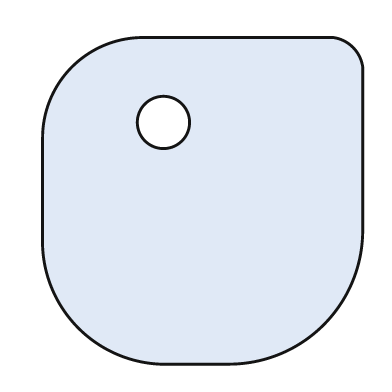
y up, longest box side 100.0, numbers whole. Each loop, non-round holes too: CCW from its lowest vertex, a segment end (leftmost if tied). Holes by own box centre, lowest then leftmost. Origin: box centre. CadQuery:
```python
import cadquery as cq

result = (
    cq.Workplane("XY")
    .moveTo(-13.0, -50.0)
    .lineTo(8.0, -50.0)
    .threePointArc((37.0, -38.0), (49.0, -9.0))
    .lineTo(49.0, 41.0)
    .threePointArc((46.0, 47.0), (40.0, 50.0))
    .lineTo(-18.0, 50.0)
    .threePointArc((-40.0, 41.0), (-49.0, 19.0))
    .lineTo(-49.0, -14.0)
    .threePointArc((-38.0, -39.0), (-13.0, -50.0))
    .close()
    .moveTo(-12.0, 24.0)
    .circle(8.0)
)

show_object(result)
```